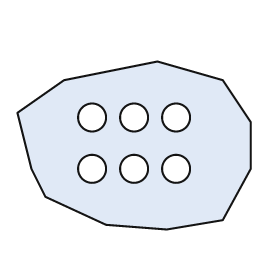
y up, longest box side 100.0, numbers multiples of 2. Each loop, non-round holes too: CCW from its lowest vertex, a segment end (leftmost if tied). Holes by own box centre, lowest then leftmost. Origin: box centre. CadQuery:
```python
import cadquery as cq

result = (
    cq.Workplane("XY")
    .moveTo(14.0, -36.0)
    .lineTo(38.0, -32.0)
    .lineTo(50.0, -10.0)
    .lineTo(50.0, 10.0)
    .lineTo(38.0, 28.0)
    .lineTo(10.0, 36.0)
    .lineTo(-30.0, 28.0)
    .lineTo(-50.0, 14.0)
    .lineTo(-44.0, -10.0)
    .lineTo(-38.0, -22.0)
    .lineTo(-12.0, -34.0)
    .close()
    .moveTo(-18.0, -10.0)
    .circle(6.0)
    .moveTo(0.0, -10.0)
    .circle(6.0)
    .moveTo(18.0, -10.0)
    .circle(6.0)
    .moveTo(-18.0, 12.0)
    .circle(6.0)
    .moveTo(0.0, 12.0)
    .circle(6.0)
    .moveTo(18.0, 12.0)
    .circle(6.0)
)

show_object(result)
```